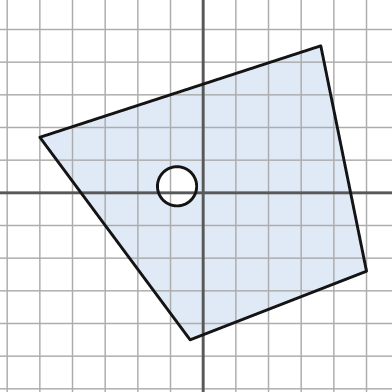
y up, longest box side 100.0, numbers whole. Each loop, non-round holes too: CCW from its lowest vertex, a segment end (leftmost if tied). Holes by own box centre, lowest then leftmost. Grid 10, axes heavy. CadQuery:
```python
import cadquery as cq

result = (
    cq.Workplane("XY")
    .moveTo(-4.0, -45.0)
    .lineTo(50.0, -24.0)
    .lineTo(36.0, 45.0)
    .lineTo(-50.0, 17.0)
    .close()
    .moveTo(-8.0, 2.0)
    .circle(6.0)
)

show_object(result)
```